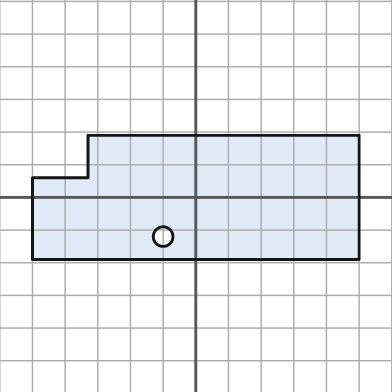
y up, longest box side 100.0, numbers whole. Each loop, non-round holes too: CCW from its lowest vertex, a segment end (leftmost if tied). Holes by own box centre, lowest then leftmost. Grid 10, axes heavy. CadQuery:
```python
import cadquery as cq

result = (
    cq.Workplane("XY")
    .moveTo(-50.0, -19.0)
    .lineTo(50.0, -19.0)
    .lineTo(50.0, 19.0)
    .lineTo(-33.0, 19.0)
    .lineTo(-33.0, 6.0)
    .lineTo(-50.0, 6.0)
    .close()
    .moveTo(-10.0, -12.0)
    .circle(3.0)
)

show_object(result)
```